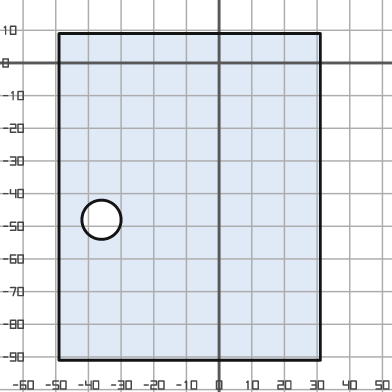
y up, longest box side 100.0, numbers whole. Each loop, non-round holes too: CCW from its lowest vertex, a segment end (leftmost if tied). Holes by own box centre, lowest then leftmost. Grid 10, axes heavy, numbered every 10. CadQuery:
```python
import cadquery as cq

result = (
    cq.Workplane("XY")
    .moveTo(-49.0, -91.0)
    .lineTo(31.0, -91.0)
    .lineTo(31.0, 9.0)
    .lineTo(-49.0, 9.0)
    .close()
    .moveTo(-36.0, -48.0)
    .circle(6.0)
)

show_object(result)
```